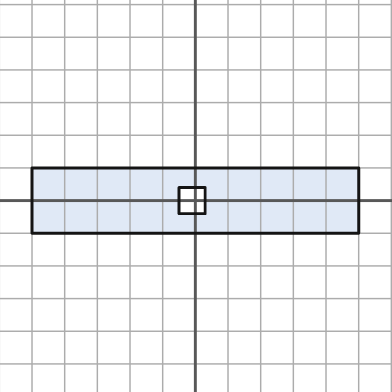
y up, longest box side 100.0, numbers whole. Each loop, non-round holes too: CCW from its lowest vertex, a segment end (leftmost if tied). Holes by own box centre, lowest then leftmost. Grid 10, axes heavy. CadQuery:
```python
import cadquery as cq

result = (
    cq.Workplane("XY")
    .moveTo(-50.0, -10.0)
    .lineTo(50.0, -10.0)
    .lineTo(50.0, 10.0)
    .lineTo(-50.0, 10.0)
    .close()
    .moveTo(-5.0, -4.0)
    .lineTo(3.0, -4.0)
    .lineTo(3.0, 4.0)
    .lineTo(-5.0, 4.0)
    .close()
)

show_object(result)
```